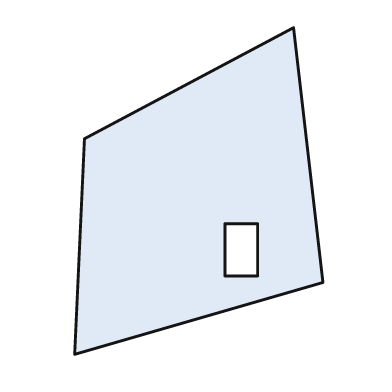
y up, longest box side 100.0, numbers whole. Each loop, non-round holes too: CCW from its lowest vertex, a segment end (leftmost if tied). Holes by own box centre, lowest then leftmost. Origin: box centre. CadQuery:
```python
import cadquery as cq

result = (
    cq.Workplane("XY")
    .moveTo(-38.0, -50.0)
    .lineTo(38.0, -28.0)
    .lineTo(29.0, 50.0)
    .lineTo(-35.0, 16.0)
    .close()
    .moveTo(8.0, -26.0)
    .lineTo(18.0, -26.0)
    .lineTo(18.0, -10.0)
    .lineTo(8.0, -10.0)
    .close()
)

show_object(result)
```